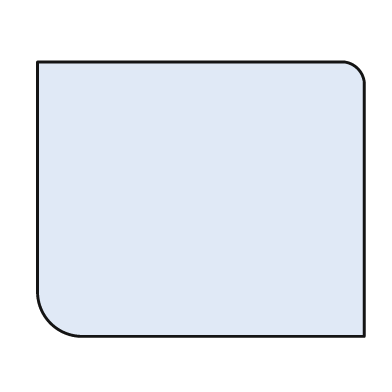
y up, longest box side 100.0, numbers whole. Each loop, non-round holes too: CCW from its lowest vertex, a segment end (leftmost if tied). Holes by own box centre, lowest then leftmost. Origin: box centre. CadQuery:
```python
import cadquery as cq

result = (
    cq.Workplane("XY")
    .moveTo(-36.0, -42.0)
    .lineTo(50.0, -42.0)
    .lineTo(50.0, 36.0)
    .threePointArc((48.0, 40.0), (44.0, 42.0))
    .lineTo(-50.0, 42.0)
    .lineTo(-50.0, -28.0)
    .threePointArc((-46.0, -38.0), (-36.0, -42.0))
    .close()
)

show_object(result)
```